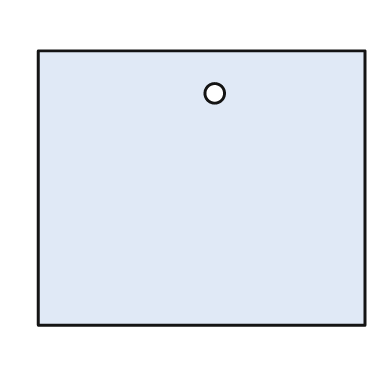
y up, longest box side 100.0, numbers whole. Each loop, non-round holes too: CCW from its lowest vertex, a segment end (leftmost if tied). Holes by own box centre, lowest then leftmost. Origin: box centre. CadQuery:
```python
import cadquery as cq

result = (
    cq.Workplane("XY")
    .moveTo(-50.0, -42.0)
    .lineTo(50.0, -42.0)
    .lineTo(50.0, 42.0)
    .lineTo(-50.0, 42.0)
    .close()
    .moveTo(4.0, 29.0)
    .circle(3.0)
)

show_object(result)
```